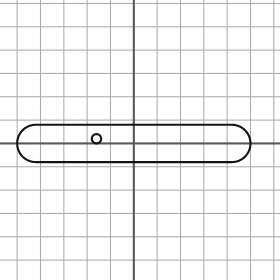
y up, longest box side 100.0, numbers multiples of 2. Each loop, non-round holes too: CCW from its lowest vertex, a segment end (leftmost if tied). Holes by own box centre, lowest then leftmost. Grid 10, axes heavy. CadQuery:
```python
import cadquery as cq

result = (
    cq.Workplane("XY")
    .moveTo(-42.0, -8.0)
    .lineTo(42.0, -8.0)
    .threePointArc((50.0, 0.0), (42.0, 8.0))
    .lineTo(-42.0, 8.0)
    .threePointArc((-50.0, 0.0), (-42.0, -8.0))
    .close()
    .moveTo(-16.0, 2.0)
    .circle(2.0)
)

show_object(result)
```